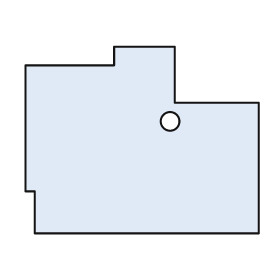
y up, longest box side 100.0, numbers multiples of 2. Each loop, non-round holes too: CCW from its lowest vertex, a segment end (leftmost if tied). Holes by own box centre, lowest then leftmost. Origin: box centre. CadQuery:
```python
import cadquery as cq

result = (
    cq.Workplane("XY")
    .moveTo(-46.0, -40.0)
    .lineTo(50.0, -40.0)
    .lineTo(50.0, 16.0)
    .lineTo(14.0, 16.0)
    .lineTo(14.0, 40.0)
    .lineTo(-12.0, 40.0)
    .lineTo(-12.0, 32.0)
    .lineTo(-50.0, 32.0)
    .lineTo(-50.0, -22.0)
    .lineTo(-46.0, -22.0)
    .close()
    .moveTo(12.0, 8.0)
    .circle(4.0)
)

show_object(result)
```